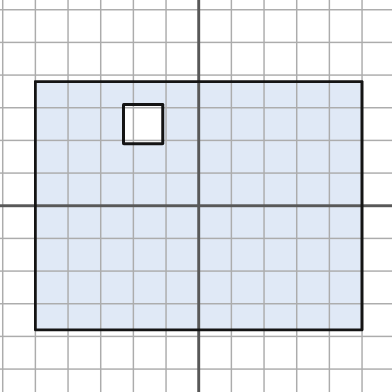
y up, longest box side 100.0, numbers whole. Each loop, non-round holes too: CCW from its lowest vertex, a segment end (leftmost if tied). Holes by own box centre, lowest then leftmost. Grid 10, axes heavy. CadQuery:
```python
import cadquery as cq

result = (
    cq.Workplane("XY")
    .moveTo(-50.0, -38.0)
    .lineTo(50.0, -38.0)
    .lineTo(50.0, 38.0)
    .lineTo(-50.0, 38.0)
    .close()
    .moveTo(-23.0, 19.0)
    .lineTo(-11.0, 19.0)
    .lineTo(-11.0, 31.0)
    .lineTo(-23.0, 31.0)
    .close()
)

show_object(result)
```